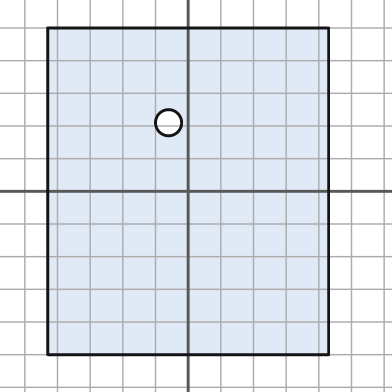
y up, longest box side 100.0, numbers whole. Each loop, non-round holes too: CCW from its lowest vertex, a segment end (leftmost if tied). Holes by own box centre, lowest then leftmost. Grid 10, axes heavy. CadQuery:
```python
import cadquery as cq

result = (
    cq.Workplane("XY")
    .moveTo(-43.0, -50.0)
    .lineTo(43.0, -50.0)
    .lineTo(43.0, 50.0)
    .lineTo(-43.0, 50.0)
    .close()
    .moveTo(-6.0, 21.0)
    .circle(4.0)
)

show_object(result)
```